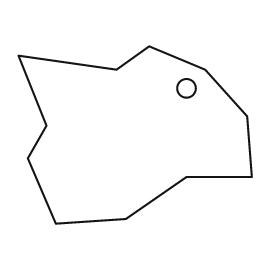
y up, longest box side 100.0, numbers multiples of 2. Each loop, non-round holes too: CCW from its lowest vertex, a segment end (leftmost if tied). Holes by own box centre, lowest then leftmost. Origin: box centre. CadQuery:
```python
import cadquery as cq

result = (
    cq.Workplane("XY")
    .moveTo(-34.0, -38.0)
    .lineTo(-4.0, -36.0)
    .lineTo(22.0, -18.0)
    .lineTo(50.0, -18.0)
    .lineTo(48.0, 8.0)
    .lineTo(30.0, 28.0)
    .lineTo(6.0, 38.0)
    .lineTo(-8.0, 28.0)
    .lineTo(-50.0, 34.0)
    .lineTo(-38.0, 4.0)
    .lineTo(-46.0, -10.0)
    .close()
    .moveTo(22.0, 20.0)
    .circle(4.0)
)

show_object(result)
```